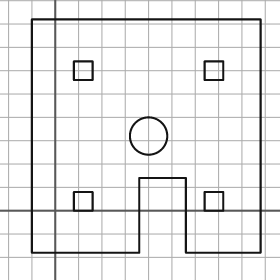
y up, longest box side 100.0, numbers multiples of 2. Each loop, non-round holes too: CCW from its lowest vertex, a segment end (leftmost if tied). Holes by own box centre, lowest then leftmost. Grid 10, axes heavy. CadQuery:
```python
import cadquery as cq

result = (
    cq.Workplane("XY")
    .moveTo(-10.0, -18.0)
    .lineTo(36.0, -18.0)
    .lineTo(36.0, 14.0)
    .lineTo(56.0, 14.0)
    .lineTo(56.0, -18.0)
    .lineTo(88.0, -18.0)
    .lineTo(88.0, 82.0)
    .lineTo(-10.0, 82.0)
    .close()
    .moveTo(8.0, 0.0)
    .lineTo(16.0, 0.0)
    .lineTo(16.0, 8.0)
    .lineTo(8.0, 8.0)
    .close()
    .moveTo(64.0, 0.0)
    .lineTo(72.0, 0.0)
    .lineTo(72.0, 8.0)
    .lineTo(64.0, 8.0)
    .close()
    .moveTo(40.0, 32.0)
    .circle(8.0)
    .moveTo(8.0, 56.0)
    .lineTo(16.0, 56.0)
    .lineTo(16.0, 64.0)
    .lineTo(8.0, 64.0)
    .close()
    .moveTo(64.0, 56.0)
    .lineTo(72.0, 56.0)
    .lineTo(72.0, 64.0)
    .lineTo(64.0, 64.0)
    .close()
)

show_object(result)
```